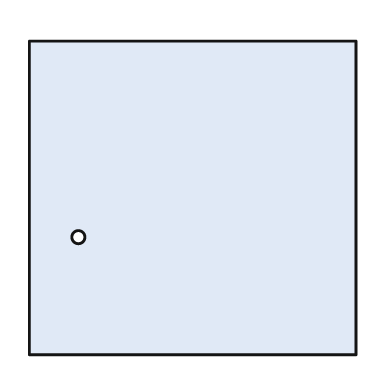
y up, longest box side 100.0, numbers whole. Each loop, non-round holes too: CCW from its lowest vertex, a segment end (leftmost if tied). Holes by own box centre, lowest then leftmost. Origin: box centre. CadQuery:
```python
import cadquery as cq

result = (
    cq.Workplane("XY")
    .moveTo(-50.0, -48.0)
    .lineTo(50.0, -48.0)
    .lineTo(50.0, 48.0)
    .lineTo(-50.0, 48.0)
    .close()
    .moveTo(-35.0, -12.0)
    .circle(2.0)
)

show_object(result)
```